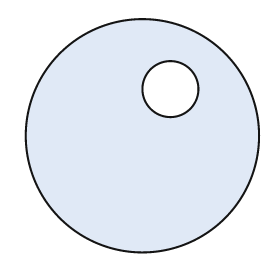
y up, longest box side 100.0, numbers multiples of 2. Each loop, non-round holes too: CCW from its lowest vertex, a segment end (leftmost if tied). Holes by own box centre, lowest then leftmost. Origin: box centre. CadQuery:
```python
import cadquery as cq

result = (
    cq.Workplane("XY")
    .moveTo(0.0, 0.0)
    .circle(50.0)
    .moveTo(12.0, 20.0)
    .circle(12.0)
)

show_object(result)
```